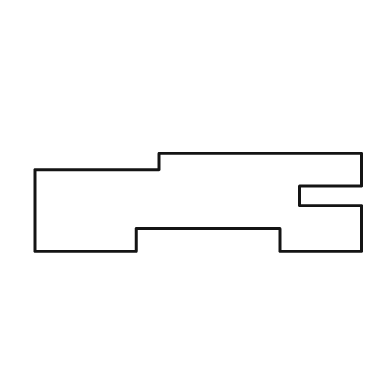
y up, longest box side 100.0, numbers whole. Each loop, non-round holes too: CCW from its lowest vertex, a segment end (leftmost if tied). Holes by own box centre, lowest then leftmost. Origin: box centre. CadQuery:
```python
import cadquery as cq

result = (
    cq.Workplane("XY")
    .moveTo(-50.0, -15.0)
    .lineTo(-19.0, -15.0)
    .lineTo(-19.0, -8.0)
    .lineTo(25.0, -8.0)
    .lineTo(25.0, -15.0)
    .lineTo(50.0, -15.0)
    .lineTo(50.0, -1.0)
    .lineTo(31.0, -1.0)
    .lineTo(31.0, 5.0)
    .lineTo(50.0, 5.0)
    .lineTo(50.0, 15.0)
    .lineTo(-12.0, 15.0)
    .lineTo(-12.0, 10.0)
    .lineTo(-50.0, 10.0)
    .close()
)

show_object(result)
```